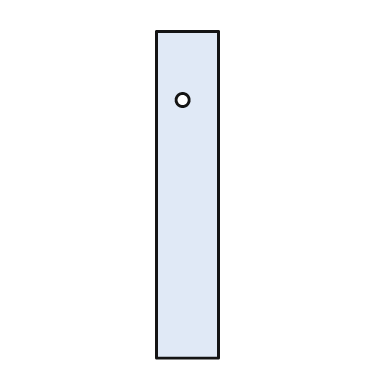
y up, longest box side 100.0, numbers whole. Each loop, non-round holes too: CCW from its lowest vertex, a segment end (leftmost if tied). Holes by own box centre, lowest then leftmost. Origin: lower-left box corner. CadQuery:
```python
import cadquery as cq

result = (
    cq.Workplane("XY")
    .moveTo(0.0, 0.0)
    .lineTo(19.0, 0.0)
    .lineTo(19.0, 100.0)
    .lineTo(0.0, 100.0)
    .close()
    .moveTo(8.0, 79.0)
    .circle(2.0)
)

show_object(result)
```